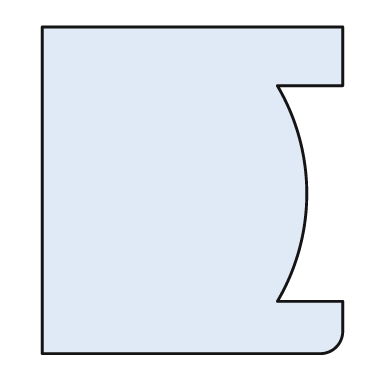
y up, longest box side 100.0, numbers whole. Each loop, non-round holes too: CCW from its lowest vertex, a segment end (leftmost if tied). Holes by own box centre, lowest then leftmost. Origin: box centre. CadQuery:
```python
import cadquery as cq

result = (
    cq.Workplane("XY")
    .moveTo(-46.0, -50.0)
    .lineTo(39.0, -50.0)
    .threePointArc((44.0, -48.0), (46.0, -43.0))
    .lineTo(46.0, -34.0)
    .lineTo(26.0, -34.0)
    .threePointArc((35.0, -1.0), (26.0, 32.0))
    .lineTo(46.0, 32.0)
    .lineTo(46.0, 50.0)
    .lineTo(-46.0, 50.0)
    .close()
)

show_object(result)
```